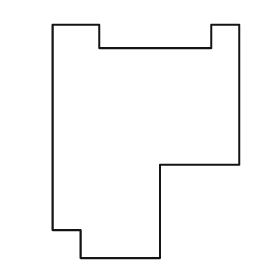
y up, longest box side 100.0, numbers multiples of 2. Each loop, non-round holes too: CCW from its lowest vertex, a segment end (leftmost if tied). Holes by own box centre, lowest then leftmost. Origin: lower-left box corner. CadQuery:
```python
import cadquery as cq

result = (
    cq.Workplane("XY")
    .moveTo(12.0, 0.0)
    .lineTo(46.0, 0.0)
    .lineTo(46.0, 40.0)
    .lineTo(80.0, 40.0)
    .lineTo(80.0, 100.0)
    .lineTo(68.0, 100.0)
    .lineTo(68.0, 90.0)
    .lineTo(20.0, 90.0)
    .lineTo(20.0, 100.0)
    .lineTo(0.0, 100.0)
    .lineTo(0.0, 12.0)
    .lineTo(12.0, 12.0)
    .close()
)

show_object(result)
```